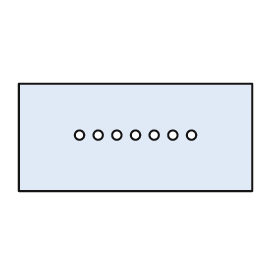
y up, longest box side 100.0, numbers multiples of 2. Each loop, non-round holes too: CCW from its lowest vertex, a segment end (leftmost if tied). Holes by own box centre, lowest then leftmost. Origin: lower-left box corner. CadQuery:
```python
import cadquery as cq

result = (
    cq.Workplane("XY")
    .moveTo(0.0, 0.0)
    .lineTo(100.0, 0.0)
    .lineTo(100.0, 46.0)
    .lineTo(0.0, 46.0)
    .close()
    .moveTo(26.0, 24.0)
    .circle(2.0)
    .moveTo(34.0, 24.0)
    .circle(2.0)
    .moveTo(42.0, 24.0)
    .circle(2.0)
    .moveTo(50.0, 24.0)
    .circle(2.0)
    .moveTo(58.0, 24.0)
    .circle(2.0)
    .moveTo(66.0, 24.0)
    .circle(2.0)
    .moveTo(74.0, 24.0)
    .circle(2.0)
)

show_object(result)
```